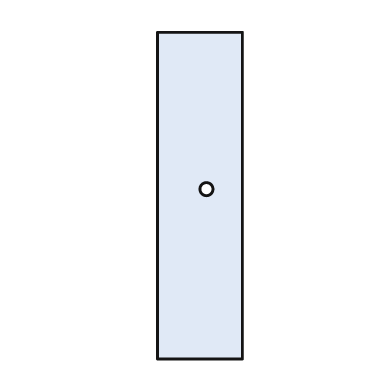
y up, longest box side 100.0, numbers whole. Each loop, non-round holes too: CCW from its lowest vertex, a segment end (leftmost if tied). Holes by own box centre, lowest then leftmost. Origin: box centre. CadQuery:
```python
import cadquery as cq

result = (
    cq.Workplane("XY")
    .moveTo(-13.0, -50.0)
    .lineTo(13.0, -50.0)
    .lineTo(13.0, 50.0)
    .lineTo(-13.0, 50.0)
    .close()
    .moveTo(2.0, 2.0)
    .circle(2.0)
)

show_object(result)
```